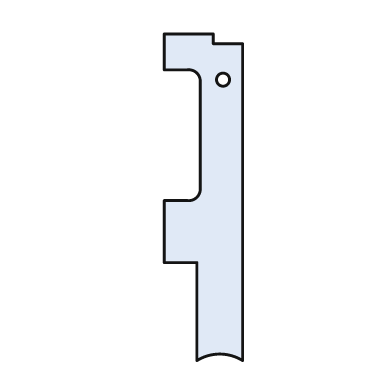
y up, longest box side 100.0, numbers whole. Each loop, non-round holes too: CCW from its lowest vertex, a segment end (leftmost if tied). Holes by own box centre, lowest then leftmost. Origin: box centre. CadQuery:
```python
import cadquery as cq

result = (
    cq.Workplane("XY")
    .moveTo(-2.0, -50.0)
    .threePointArc((5.0, -48.0), (12.0, -50.0))
    .lineTo(12.0, 47.0)
    .lineTo(3.0, 47.0)
    .lineTo(3.0, 50.0)
    .lineTo(-12.0, 50.0)
    .lineTo(-12.0, 39.0)
    .lineTo(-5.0, 39.0)
    .threePointArc((-2.0, 38.0), (-1.0, 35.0))
    .lineTo(-1.0, 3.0)
    .threePointArc((-2.0, 0.0), (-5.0, -1.0))
    .lineTo(-12.0, -1.0)
    .lineTo(-12.0, -20.0)
    .lineTo(-2.0, -20.0)
    .close()
    .moveTo(6.0, 36.0)
    .circle(2.0)
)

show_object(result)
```